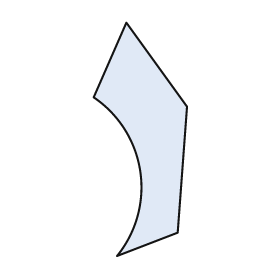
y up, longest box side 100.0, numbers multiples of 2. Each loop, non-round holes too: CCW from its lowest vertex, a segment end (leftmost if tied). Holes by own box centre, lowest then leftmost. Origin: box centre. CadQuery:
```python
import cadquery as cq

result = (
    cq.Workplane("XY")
    .moveTo(-10.0, -50.0)
    .lineTo(16.0, -40.0)
    .lineTo(20.0, 14.0)
    .lineTo(-6.0, 50.0)
    .lineTo(-20.0, 18.0)
    .threePointArc((0.0, -14.0), (-10.0, -50.0))
    .close()
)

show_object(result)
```